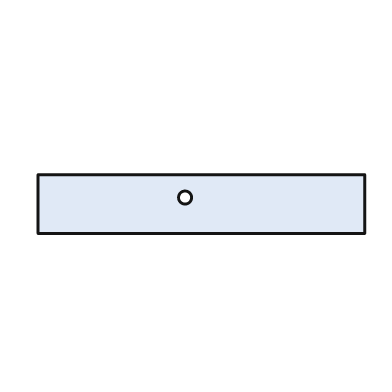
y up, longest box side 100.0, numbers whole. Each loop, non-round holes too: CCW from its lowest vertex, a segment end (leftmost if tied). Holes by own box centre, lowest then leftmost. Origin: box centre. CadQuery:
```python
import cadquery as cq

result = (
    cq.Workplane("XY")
    .moveTo(-50.0, -9.0)
    .lineTo(50.0, -9.0)
    .lineTo(50.0, 9.0)
    .lineTo(-50.0, 9.0)
    .close()
    .moveTo(-5.0, 2.0)
    .circle(2.0)
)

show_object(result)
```